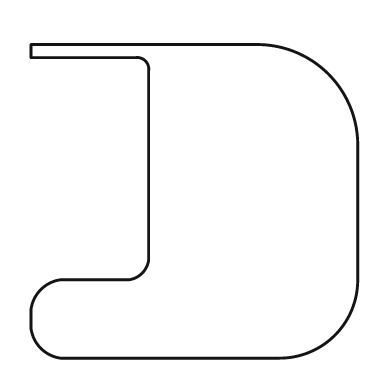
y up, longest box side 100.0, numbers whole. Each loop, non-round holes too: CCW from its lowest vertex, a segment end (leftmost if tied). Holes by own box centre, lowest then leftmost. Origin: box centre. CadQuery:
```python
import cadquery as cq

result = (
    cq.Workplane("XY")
    .moveTo(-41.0, -48.0)
    .lineTo(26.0, -48.0)
    .threePointArc((43.0, -41.0), (50.0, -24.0))
    .lineTo(50.0, 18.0)
    .threePointArc((41.0, 39.0), (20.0, 48.0))
    .lineTo(-50.0, 48.0)
    .lineTo(-50.0, 44.0)
    .lineTo(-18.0, 44.0)
    .threePointArc((-15.0, 43.0), (-14.0, 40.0))
    .lineTo(-14.0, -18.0)
    .threePointArc((-16.0, -22.0), (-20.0, -24.0))
    .lineTo(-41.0, -24.0)
    .threePointArc((-47.0, -27.0), (-50.0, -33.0))
    .lineTo(-50.0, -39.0)
    .threePointArc((-47.0, -45.0), (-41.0, -48.0))
    .close()
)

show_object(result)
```